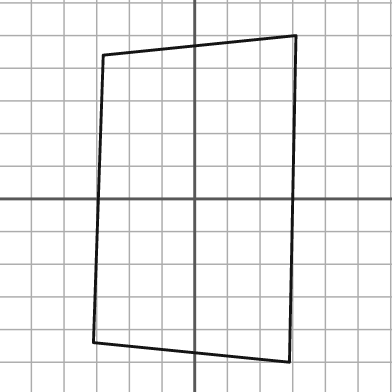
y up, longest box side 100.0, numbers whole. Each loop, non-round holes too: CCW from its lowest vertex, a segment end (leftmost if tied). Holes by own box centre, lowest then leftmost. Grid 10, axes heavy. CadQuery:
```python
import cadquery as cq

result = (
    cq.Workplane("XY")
    .moveTo(29.0, -50.0)
    .lineTo(31.0, 50.0)
    .lineTo(-28.0, 44.0)
    .lineTo(-31.0, -44.0)
    .close()
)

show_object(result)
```